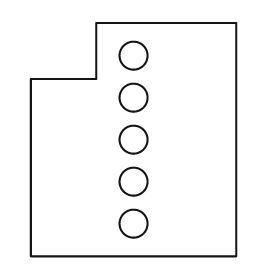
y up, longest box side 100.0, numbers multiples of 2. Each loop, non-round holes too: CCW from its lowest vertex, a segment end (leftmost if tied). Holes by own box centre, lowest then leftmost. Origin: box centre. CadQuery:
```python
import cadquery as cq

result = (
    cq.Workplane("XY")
    .moveTo(-44.0, -50.0)
    .lineTo(44.0, -50.0)
    .lineTo(44.0, 50.0)
    .lineTo(-16.0, 50.0)
    .lineTo(-16.0, 26.0)
    .lineTo(-44.0, 26.0)
    .close()
    .moveTo(0.0, -36.0)
    .circle(6.0)
    .moveTo(0.0, -18.0)
    .circle(6.0)
    .moveTo(0.0, 0.0)
    .circle(6.0)
    .moveTo(0.0, 18.0)
    .circle(6.0)
    .moveTo(0.0, 36.0)
    .circle(6.0)
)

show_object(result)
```